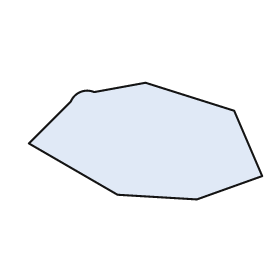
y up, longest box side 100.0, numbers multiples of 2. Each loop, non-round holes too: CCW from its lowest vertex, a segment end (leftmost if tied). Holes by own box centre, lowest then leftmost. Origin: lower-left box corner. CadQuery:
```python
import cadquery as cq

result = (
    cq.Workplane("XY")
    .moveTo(72.0, 0.0)
    .lineTo(100.0, 10.0)
    .lineTo(88.0, 38.0)
    .lineTo(50.0, 50.0)
    .lineTo(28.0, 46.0)
    .threePointArc((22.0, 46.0), (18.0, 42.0))
    .lineTo(0.0, 24.0)
    .lineTo(38.0, 2.0)
    .close()
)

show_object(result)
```